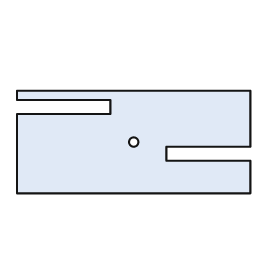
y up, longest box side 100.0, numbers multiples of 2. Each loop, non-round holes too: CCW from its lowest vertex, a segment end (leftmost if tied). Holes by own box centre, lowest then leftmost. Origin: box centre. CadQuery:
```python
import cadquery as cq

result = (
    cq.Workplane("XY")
    .moveTo(-50.0, -22.0)
    .lineTo(50.0, -22.0)
    .lineTo(50.0, -8.0)
    .lineTo(14.0, -8.0)
    .lineTo(14.0, -2.0)
    .lineTo(50.0, -2.0)
    .lineTo(50.0, 22.0)
    .lineTo(-50.0, 22.0)
    .lineTo(-50.0, 18.0)
    .lineTo(-10.0, 18.0)
    .lineTo(-10.0, 12.0)
    .lineTo(-50.0, 12.0)
    .close()
    .moveTo(0.0, 0.0)
    .circle(2.0)
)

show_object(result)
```